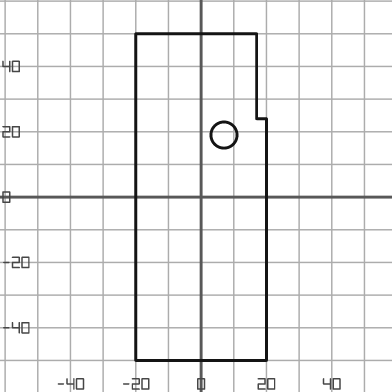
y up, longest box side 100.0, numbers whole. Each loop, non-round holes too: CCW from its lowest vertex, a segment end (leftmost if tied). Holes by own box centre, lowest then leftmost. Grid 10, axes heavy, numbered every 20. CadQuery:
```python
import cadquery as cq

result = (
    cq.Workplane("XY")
    .moveTo(-20.0, -50.0)
    .lineTo(20.0, -50.0)
    .lineTo(20.0, 24.0)
    .lineTo(17.0, 24.0)
    .lineTo(17.0, 50.0)
    .lineTo(-20.0, 50.0)
    .close()
    .moveTo(7.0, 19.0)
    .circle(4.0)
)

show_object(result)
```